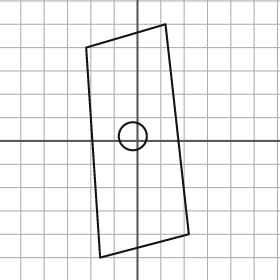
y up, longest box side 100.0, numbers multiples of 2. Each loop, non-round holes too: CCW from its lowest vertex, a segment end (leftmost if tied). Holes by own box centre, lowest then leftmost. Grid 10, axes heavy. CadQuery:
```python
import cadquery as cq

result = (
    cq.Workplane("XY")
    .moveTo(-16.0, -50.0)
    .lineTo(22.0, -40.0)
    .lineTo(12.0, 50.0)
    .lineTo(-22.0, 40.0)
    .close()
    .moveTo(-2.0, 2.0)
    .circle(6.0)
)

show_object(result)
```